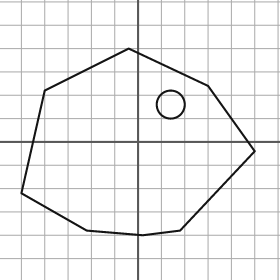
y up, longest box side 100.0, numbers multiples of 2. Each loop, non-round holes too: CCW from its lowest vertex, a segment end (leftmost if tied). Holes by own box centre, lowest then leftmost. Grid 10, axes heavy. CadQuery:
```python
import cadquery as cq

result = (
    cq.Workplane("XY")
    .moveTo(2.0, -40.0)
    .lineTo(18.0, -38.0)
    .lineTo(50.0, -4.0)
    .lineTo(30.0, 24.0)
    .lineTo(-4.0, 40.0)
    .lineTo(-40.0, 22.0)
    .lineTo(-50.0, -22.0)
    .lineTo(-22.0, -38.0)
    .close()
    .moveTo(14.0, 16.0)
    .circle(6.0)
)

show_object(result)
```